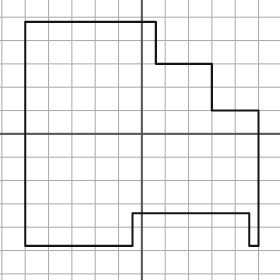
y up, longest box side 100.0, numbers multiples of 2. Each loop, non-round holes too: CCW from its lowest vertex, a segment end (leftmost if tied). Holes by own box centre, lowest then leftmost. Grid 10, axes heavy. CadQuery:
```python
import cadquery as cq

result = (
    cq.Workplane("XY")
    .moveTo(-50.0, -48.0)
    .lineTo(-4.0, -48.0)
    .lineTo(-4.0, -34.0)
    .lineTo(46.0, -34.0)
    .lineTo(46.0, -48.0)
    .lineTo(50.0, -48.0)
    .lineTo(50.0, 10.0)
    .lineTo(30.0, 10.0)
    .lineTo(30.0, 30.0)
    .lineTo(6.0, 30.0)
    .lineTo(6.0, 48.0)
    .lineTo(-50.0, 48.0)
    .close()
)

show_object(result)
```